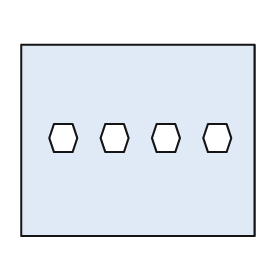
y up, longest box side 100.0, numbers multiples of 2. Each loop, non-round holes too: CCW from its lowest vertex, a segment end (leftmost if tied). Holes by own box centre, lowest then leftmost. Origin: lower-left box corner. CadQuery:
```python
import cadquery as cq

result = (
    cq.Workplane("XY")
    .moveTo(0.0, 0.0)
    .lineTo(100.0, 0.0)
    .lineTo(100.0, 82.0)
    .lineTo(0.0, 82.0)
    .close()
    .moveTo(14.0, 36.0)
    .lineTo(22.0, 36.0)
    .lineTo(24.0, 42.0)
    .lineTo(22.0, 48.0)
    .lineTo(14.0, 48.0)
    .lineTo(12.0, 42.0)
    .close()
    .moveTo(36.0, 36.0)
    .lineTo(44.0, 36.0)
    .lineTo(46.0, 42.0)
    .lineTo(44.0, 48.0)
    .lineTo(36.0, 48.0)
    .lineTo(34.0, 42.0)
    .close()
    .moveTo(58.0, 36.0)
    .lineTo(66.0, 36.0)
    .lineTo(68.0, 42.0)
    .lineTo(66.0, 48.0)
    .lineTo(58.0, 48.0)
    .lineTo(56.0, 42.0)
    .close()
    .moveTo(80.0, 36.0)
    .lineTo(88.0, 36.0)
    .lineTo(90.0, 42.0)
    .lineTo(88.0, 48.0)
    .lineTo(80.0, 48.0)
    .lineTo(78.0, 42.0)
    .close()
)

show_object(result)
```